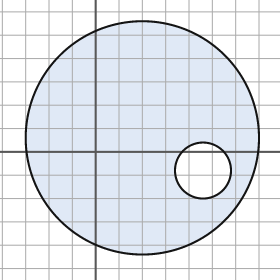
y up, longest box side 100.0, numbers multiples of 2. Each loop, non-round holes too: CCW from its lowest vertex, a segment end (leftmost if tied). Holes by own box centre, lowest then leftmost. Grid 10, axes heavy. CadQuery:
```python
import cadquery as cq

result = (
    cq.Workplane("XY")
    .moveTo(20.0, 6.0)
    .circle(50.0)
    .moveTo(46.0, -8.0)
    .circle(12.0)
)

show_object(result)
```